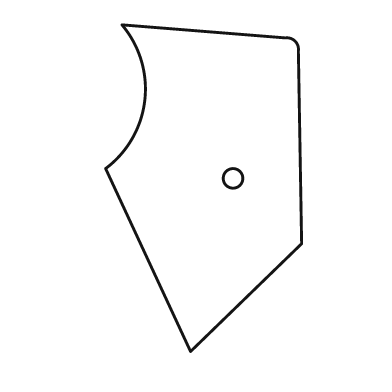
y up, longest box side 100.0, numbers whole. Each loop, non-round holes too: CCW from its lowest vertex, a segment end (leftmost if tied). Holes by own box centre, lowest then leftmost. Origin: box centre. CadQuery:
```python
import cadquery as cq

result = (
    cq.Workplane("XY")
    .moveTo(-4.0, -50.0)
    .lineTo(30.0, -17.0)
    .lineTo(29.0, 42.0)
    .threePointArc((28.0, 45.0), (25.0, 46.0))
    .lineTo(-25.0, 50.0)
    .threePointArc((-18.0, 27.0), (-30.0, 6.0))
    .close()
    .moveTo(9.0, 3.0)
    .circle(3.0)
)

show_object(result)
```